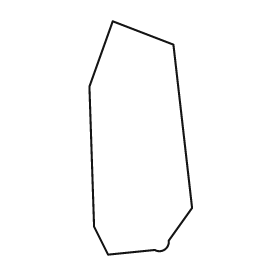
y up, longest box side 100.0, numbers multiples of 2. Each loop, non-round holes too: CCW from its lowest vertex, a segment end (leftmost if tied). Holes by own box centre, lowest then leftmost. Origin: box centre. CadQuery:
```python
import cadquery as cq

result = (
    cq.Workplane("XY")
    .moveTo(-14.0, -50.0)
    .lineTo(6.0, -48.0)
    .threePointArc((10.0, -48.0), (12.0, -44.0))
    .lineTo(22.0, -30.0)
    .lineTo(14.0, 40.0)
    .lineTo(-12.0, 50.0)
    .lineTo(-22.0, 22.0)
    .lineTo(-20.0, -38.0)
    .close()
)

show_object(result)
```